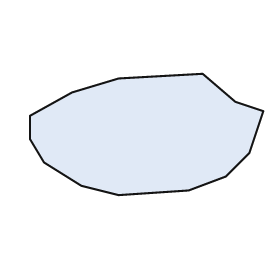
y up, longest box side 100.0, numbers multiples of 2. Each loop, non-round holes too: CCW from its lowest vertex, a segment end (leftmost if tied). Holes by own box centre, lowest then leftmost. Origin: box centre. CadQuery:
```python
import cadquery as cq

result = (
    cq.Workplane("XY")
    .moveTo(-12.0, -26.0)
    .lineTo(18.0, -24.0)
    .lineTo(34.0, -18.0)
    .lineTo(44.0, -8.0)
    .lineTo(50.0, 10.0)
    .lineTo(38.0, 14.0)
    .lineTo(24.0, 26.0)
    .lineTo(-12.0, 24.0)
    .lineTo(-32.0, 18.0)
    .lineTo(-50.0, 8.0)
    .lineTo(-50.0, -2.0)
    .lineTo(-44.0, -12.0)
    .lineTo(-28.0, -22.0)
    .close()
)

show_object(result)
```